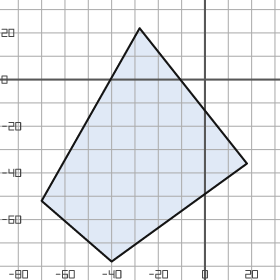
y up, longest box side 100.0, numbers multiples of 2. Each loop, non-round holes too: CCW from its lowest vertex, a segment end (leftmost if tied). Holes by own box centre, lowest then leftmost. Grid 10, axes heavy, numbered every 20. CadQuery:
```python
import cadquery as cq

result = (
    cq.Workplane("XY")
    .moveTo(-40.0, -78.0)
    .lineTo(18.0, -36.0)
    .lineTo(-28.0, 22.0)
    .lineTo(-70.0, -52.0)
    .close()
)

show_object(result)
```